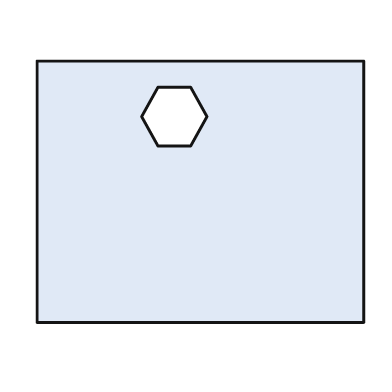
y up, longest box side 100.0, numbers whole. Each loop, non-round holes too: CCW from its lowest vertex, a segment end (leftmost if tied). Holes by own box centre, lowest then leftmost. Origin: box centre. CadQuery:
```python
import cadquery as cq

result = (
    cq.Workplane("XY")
    .moveTo(-50.0, -40.0)
    .lineTo(50.0, -40.0)
    .lineTo(50.0, 40.0)
    .lineTo(-50.0, 40.0)
    .close()
    .moveTo(-13.0, 14.0)
    .lineTo(-3.0, 14.0)
    .lineTo(2.0, 23.0)
    .lineTo(-3.0, 32.0)
    .lineTo(-13.0, 32.0)
    .lineTo(-18.0, 23.0)
    .close()
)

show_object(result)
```